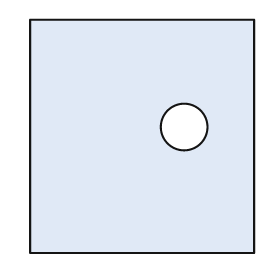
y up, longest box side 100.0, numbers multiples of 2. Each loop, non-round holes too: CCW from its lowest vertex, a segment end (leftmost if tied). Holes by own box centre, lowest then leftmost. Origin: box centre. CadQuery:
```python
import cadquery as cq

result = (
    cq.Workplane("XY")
    .moveTo(-48.0, -50.0)
    .lineTo(48.0, -50.0)
    .lineTo(48.0, 50.0)
    .lineTo(-48.0, 50.0)
    .close()
    .moveTo(18.0, 4.0)
    .circle(10.0)
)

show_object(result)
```